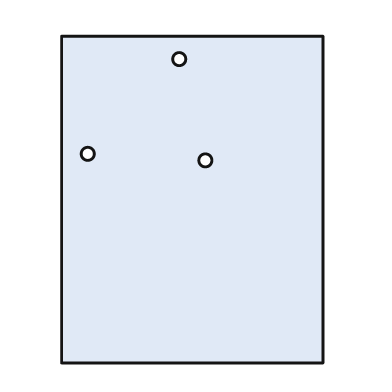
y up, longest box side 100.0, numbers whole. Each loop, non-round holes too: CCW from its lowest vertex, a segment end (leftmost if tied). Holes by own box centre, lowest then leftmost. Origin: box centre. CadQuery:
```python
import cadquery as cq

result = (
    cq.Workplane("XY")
    .moveTo(-40.0, -50.0)
    .lineTo(40.0, -50.0)
    .lineTo(40.0, 50.0)
    .lineTo(-40.0, 50.0)
    .close()
    .moveTo(4.0, 12.0)
    .circle(2.0)
    .moveTo(-32.0, 14.0)
    .circle(2.0)
    .moveTo(-4.0, 43.0)
    .circle(2.0)
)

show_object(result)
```